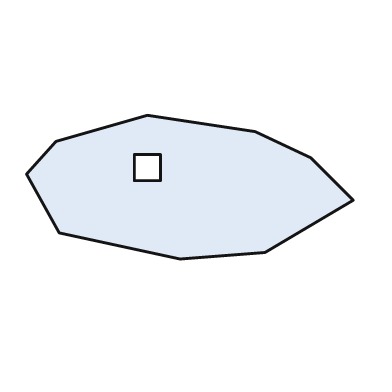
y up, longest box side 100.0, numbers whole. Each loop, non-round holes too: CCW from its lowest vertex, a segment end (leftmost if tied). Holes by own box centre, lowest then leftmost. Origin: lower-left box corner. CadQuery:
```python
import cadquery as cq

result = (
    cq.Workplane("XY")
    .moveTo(47.0, 0.0)
    .lineTo(73.0, 2.0)
    .lineTo(100.0, 18.0)
    .lineTo(87.0, 31.0)
    .lineTo(70.0, 39.0)
    .lineTo(37.0, 44.0)
    .lineTo(9.0, 36.0)
    .lineTo(0.0, 26.0)
    .lineTo(10.0, 8.0)
    .close()
    .moveTo(33.0, 24.0)
    .lineTo(41.0, 24.0)
    .lineTo(41.0, 32.0)
    .lineTo(33.0, 32.0)
    .close()
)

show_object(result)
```